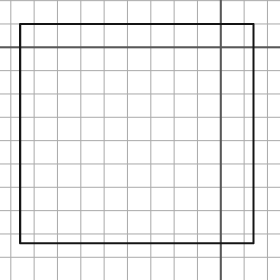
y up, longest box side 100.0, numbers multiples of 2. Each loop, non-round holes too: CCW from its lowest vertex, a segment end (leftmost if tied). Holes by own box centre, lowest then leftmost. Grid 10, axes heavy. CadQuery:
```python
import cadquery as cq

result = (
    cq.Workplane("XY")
    .moveTo(-86.0, -84.0)
    .lineTo(14.0, -84.0)
    .lineTo(14.0, 10.0)
    .lineTo(-86.0, 10.0)
    .close()
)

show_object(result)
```